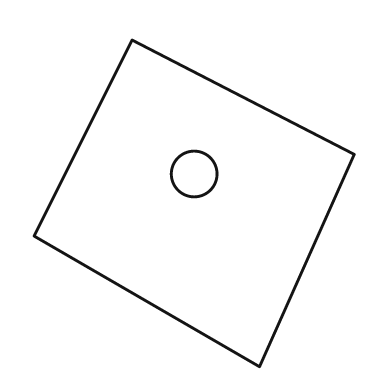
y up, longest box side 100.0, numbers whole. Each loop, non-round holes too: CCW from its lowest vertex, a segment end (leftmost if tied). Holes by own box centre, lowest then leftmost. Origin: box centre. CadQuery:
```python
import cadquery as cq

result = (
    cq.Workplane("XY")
    .moveTo(20.0, -50.0)
    .lineTo(49.0, 15.0)
    .lineTo(-19.0, 50.0)
    .lineTo(-49.0, -10.0)
    .close()
    .moveTo(0.0, 9.0)
    .circle(7.0)
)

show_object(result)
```